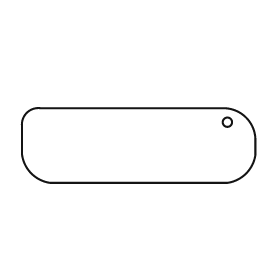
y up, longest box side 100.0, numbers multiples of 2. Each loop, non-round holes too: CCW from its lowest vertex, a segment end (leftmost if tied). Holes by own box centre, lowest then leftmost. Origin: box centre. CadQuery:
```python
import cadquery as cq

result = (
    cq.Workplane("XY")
    .moveTo(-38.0, -16.0)
    .lineTo(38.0, -16.0)
    .threePointArc((46.0, -12.0), (50.0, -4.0))
    .lineTo(50.0, 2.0)
    .threePointArc((46.0, 12.0), (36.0, 16.0))
    .lineTo(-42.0, 16.0)
    .threePointArc((-48.0, 14.0), (-50.0, 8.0))
    .lineTo(-50.0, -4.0)
    .threePointArc((-46.0, -12.0), (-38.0, -16.0))
    .close()
    .moveTo(38.0, 10.0)
    .circle(2.0)
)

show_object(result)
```